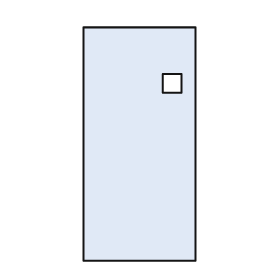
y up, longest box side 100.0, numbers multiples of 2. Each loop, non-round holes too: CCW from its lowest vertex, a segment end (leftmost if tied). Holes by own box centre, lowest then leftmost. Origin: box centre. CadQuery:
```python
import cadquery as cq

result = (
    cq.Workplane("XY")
    .moveTo(-24.0, -50.0)
    .lineTo(24.0, -50.0)
    .lineTo(24.0, 50.0)
    .lineTo(-24.0, 50.0)
    .close()
    .moveTo(10.0, 22.0)
    .lineTo(18.0, 22.0)
    .lineTo(18.0, 30.0)
    .lineTo(10.0, 30.0)
    .close()
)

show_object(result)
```